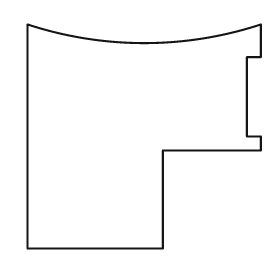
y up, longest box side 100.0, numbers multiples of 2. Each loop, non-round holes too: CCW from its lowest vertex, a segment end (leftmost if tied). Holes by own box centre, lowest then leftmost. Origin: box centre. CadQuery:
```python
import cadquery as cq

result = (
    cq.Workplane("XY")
    .moveTo(-50.0, -48.0)
    .lineTo(8.0, -48.0)
    .lineTo(8.0, -6.0)
    .lineTo(50.0, -6.0)
    .lineTo(50.0, 0.0)
    .lineTo(44.0, 0.0)
    .lineTo(44.0, 34.0)
    .lineTo(50.0, 34.0)
    .lineTo(50.0, 48.0)
    .threePointArc((0.0, 40.0), (-50.0, 48.0))
    .close()
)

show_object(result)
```